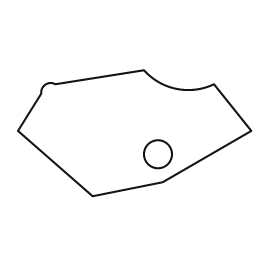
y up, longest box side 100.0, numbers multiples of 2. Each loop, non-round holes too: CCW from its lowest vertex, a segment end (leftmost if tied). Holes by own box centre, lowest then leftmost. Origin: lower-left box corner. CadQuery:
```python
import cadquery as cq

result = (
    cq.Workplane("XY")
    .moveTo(32.0, 0.0)
    .lineTo(62.0, 6.0)
    .lineTo(100.0, 28.0)
    .lineTo(84.0, 48.0)
    .threePointArc((68.0, 46.0), (54.0, 54.0))
    .lineTo(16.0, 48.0)
    .threePointArc((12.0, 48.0), (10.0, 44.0))
    .lineTo(0.0, 28.0)
    .close()
    .moveTo(60.0, 18.0)
    .circle(6.0)
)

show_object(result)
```